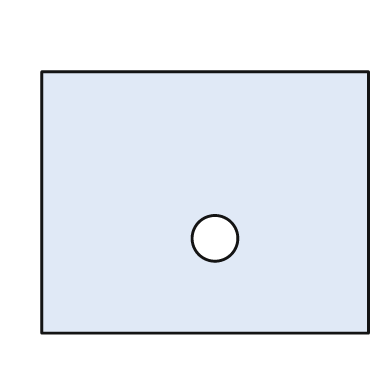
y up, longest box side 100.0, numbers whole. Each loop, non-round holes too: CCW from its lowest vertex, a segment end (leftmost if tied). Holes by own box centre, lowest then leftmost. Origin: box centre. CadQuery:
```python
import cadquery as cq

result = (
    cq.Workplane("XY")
    .moveTo(-50.0, -40.0)
    .lineTo(50.0, -40.0)
    .lineTo(50.0, 40.0)
    .lineTo(-50.0, 40.0)
    .close()
    .moveTo(3.0, -11.0)
    .circle(7.0)
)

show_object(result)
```